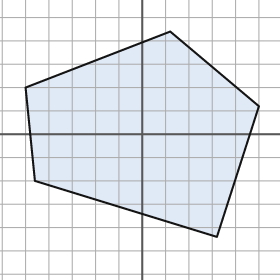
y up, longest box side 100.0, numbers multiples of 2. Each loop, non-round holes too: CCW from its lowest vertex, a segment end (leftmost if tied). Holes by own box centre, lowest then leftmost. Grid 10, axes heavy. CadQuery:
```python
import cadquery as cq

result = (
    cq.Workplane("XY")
    .moveTo(32.0, -44.0)
    .lineTo(50.0, 12.0)
    .lineTo(12.0, 44.0)
    .lineTo(-50.0, 20.0)
    .lineTo(-46.0, -20.0)
    .close()
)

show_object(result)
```